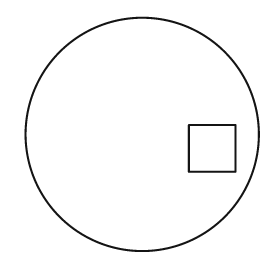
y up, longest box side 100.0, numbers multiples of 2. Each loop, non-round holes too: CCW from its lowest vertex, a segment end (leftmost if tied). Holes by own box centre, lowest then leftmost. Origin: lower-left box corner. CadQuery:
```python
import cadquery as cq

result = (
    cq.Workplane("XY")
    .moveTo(50.0, 50.0)
    .circle(50.0)
    .moveTo(70.0, 34.0)
    .lineTo(90.0, 34.0)
    .lineTo(90.0, 54.0)
    .lineTo(70.0, 54.0)
    .close()
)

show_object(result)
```